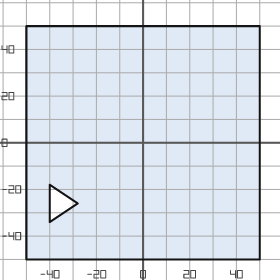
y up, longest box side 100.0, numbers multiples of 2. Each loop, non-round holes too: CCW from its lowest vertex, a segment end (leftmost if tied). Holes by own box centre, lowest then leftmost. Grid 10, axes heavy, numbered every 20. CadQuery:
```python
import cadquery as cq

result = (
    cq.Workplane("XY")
    .moveTo(-50.0, -50.0)
    .lineTo(50.0, -50.0)
    .lineTo(50.0, 50.0)
    .lineTo(-50.0, 50.0)
    .close()
    .moveTo(-40.0, -34.0)
    .lineTo(-28.0, -26.0)
    .lineTo(-40.0, -18.0)
    .close()
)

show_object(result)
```